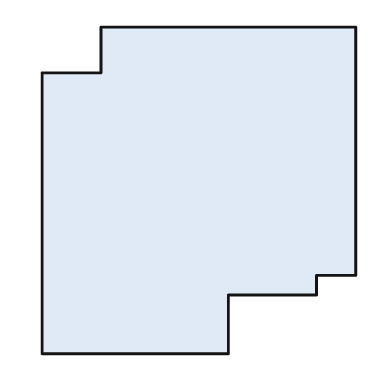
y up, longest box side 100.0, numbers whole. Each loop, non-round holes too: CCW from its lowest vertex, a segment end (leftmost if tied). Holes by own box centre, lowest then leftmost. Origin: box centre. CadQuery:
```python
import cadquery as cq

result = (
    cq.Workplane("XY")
    .moveTo(-48.0, -50.0)
    .lineTo(9.0, -50.0)
    .lineTo(9.0, -32.0)
    .lineTo(36.0, -32.0)
    .lineTo(36.0, -26.0)
    .lineTo(48.0, -26.0)
    .lineTo(48.0, 50.0)
    .lineTo(-30.0, 50.0)
    .lineTo(-30.0, 36.0)
    .lineTo(-48.0, 36.0)
    .close()
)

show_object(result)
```